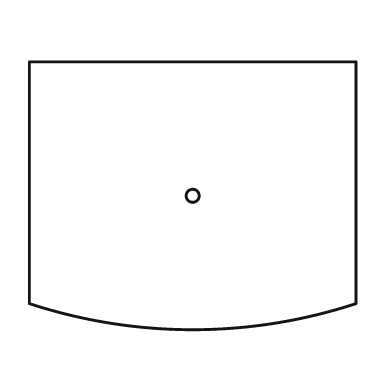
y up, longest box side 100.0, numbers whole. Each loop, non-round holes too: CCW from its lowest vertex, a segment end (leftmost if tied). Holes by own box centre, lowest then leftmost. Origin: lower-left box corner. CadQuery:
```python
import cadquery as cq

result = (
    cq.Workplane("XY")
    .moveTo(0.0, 8.0)
    .threePointArc((50.0, 0.0), (100.0, 8.0))
    .lineTo(100.0, 82.0)
    .lineTo(0.0, 82.0)
    .close()
    .moveTo(50.0, 41.0)
    .circle(2.0)
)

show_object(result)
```